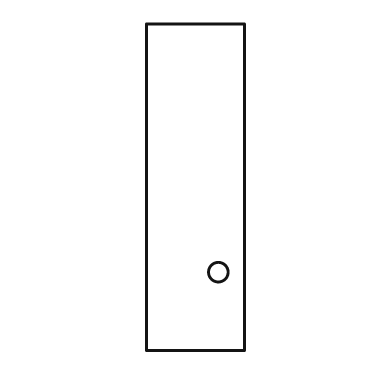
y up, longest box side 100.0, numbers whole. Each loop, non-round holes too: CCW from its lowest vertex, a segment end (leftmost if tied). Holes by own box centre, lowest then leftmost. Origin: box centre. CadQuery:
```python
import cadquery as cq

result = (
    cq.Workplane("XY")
    .moveTo(-15.0, -50.0)
    .lineTo(15.0, -50.0)
    .lineTo(15.0, 50.0)
    .lineTo(-15.0, 50.0)
    .close()
    .moveTo(7.0, -26.0)
    .circle(3.0)
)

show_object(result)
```